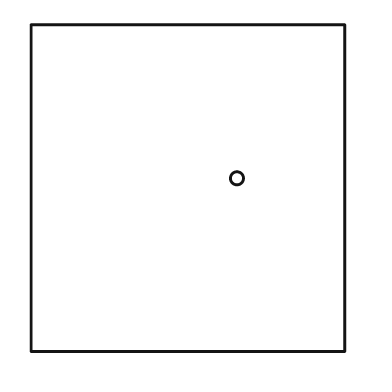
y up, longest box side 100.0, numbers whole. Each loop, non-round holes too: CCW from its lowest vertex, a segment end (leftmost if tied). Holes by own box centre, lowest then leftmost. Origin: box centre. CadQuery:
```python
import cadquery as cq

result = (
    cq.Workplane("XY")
    .moveTo(-48.0, -50.0)
    .lineTo(48.0, -50.0)
    .lineTo(48.0, 50.0)
    .lineTo(-48.0, 50.0)
    .close()
    .moveTo(15.0, 3.0)
    .circle(2.0)
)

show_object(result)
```